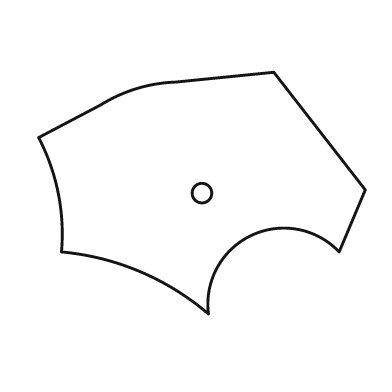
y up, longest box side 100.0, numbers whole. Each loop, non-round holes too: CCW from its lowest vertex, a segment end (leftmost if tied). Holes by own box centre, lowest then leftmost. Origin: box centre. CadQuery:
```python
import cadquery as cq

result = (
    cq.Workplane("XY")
    .moveTo(2.0, -37.0)
    .threePointArc((15.0, -13.0), (42.0, -18.0))
    .lineTo(50.0, 1.0)
    .lineTo(22.0, 37.0)
    .lineTo(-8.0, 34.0)
    .threePointArc((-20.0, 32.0), (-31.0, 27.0))
    .lineTo(-50.0, 17.0)
    .threePointArc((-44.0, 0.0), (-43.0, -18.0))
    .threePointArc((-19.0, -24.0), (2.0, -37.0))
    .close()
    .moveTo(0.0, 0.0)
    .circle(3.0)
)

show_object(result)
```